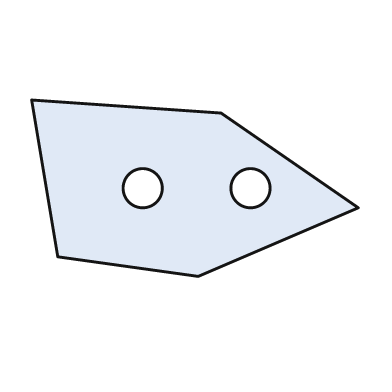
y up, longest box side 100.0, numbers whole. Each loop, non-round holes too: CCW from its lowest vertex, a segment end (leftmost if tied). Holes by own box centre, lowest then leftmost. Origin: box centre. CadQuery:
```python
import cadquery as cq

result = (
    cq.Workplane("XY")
    .moveTo(1.0, -27.0)
    .lineTo(50.0, -6.0)
    .lineTo(8.0, 23.0)
    .lineTo(-50.0, 27.0)
    .lineTo(-42.0, -21.0)
    .close()
    .moveTo(-16.0, 0.0)
    .circle(6.0)
    .moveTo(17.0, 0.0)
    .circle(6.0)
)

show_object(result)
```